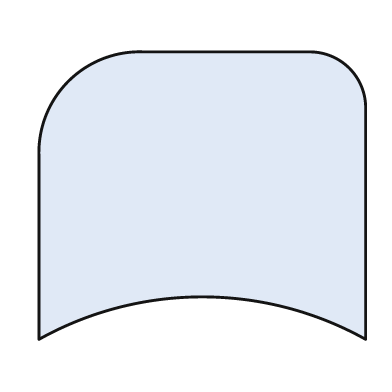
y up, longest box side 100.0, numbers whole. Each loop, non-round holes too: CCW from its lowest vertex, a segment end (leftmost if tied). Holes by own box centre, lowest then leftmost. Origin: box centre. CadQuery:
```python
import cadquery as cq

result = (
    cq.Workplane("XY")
    .moveTo(-50.0, -44.0)
    .threePointArc((0.0, -31.0), (50.0, -44.0))
    .lineTo(50.0, 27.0)
    .threePointArc((45.0, 39.0), (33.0, 44.0))
    .lineTo(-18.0, 44.0)
    .threePointArc((-41.0, 35.0), (-50.0, 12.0))
    .close()
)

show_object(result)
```